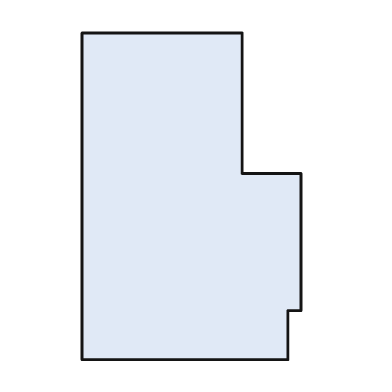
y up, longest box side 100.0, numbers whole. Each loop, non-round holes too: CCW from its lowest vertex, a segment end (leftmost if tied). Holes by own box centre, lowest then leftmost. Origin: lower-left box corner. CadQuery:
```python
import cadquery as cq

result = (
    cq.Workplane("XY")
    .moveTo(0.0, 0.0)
    .lineTo(63.0, 0.0)
    .lineTo(63.0, 15.0)
    .lineTo(67.0, 15.0)
    .lineTo(67.0, 57.0)
    .lineTo(49.0, 57.0)
    .lineTo(49.0, 100.0)
    .lineTo(0.0, 100.0)
    .close()
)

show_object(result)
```